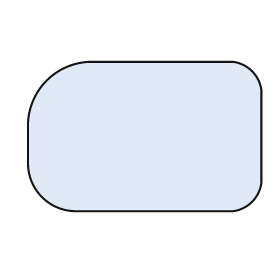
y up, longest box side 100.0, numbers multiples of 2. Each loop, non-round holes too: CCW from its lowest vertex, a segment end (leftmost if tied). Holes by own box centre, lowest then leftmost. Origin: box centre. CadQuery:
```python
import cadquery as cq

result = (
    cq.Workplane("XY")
    .moveTo(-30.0, -32.0)
    .lineTo(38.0, -32.0)
    .threePointArc((46.0, -28.0), (50.0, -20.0))
    .lineTo(50.0, 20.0)
    .threePointArc((46.0, 28.0), (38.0, 32.0))
    .lineTo(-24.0, 32.0)
    .threePointArc((-42.0, 24.0), (-50.0, 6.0))
    .lineTo(-50.0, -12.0)
    .threePointArc((-44.0, -26.0), (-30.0, -32.0))
    .close()
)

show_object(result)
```